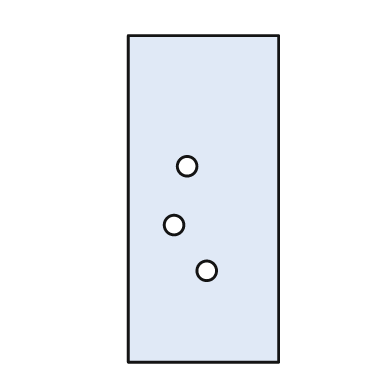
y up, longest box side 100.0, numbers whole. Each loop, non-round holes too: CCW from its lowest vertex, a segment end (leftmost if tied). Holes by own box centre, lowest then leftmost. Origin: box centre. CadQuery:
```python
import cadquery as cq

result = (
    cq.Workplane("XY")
    .moveTo(-23.0, -50.0)
    .lineTo(23.0, -50.0)
    .lineTo(23.0, 50.0)
    .lineTo(-23.0, 50.0)
    .close()
    .moveTo(1.0, -22.0)
    .circle(3.0)
    .moveTo(-9.0, -8.0)
    .circle(3.0)
    .moveTo(-5.0, 10.0)
    .circle(3.0)
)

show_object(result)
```